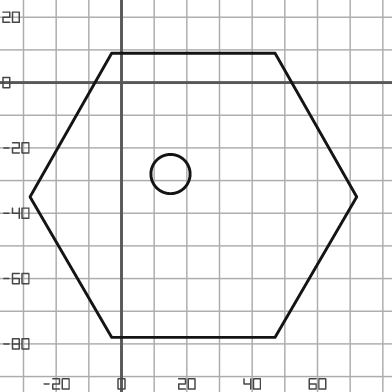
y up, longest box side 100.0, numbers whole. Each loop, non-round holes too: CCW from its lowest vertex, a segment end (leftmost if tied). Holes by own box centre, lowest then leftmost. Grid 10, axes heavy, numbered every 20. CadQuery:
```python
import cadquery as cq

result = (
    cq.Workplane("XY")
    .moveTo(-3.0, -78.0)
    .lineTo(47.0, -78.0)
    .lineTo(72.0, -35.0)
    .lineTo(47.0, 9.0)
    .lineTo(-3.0, 9.0)
    .lineTo(-28.0, -35.0)
    .close()
    .moveTo(15.0, -28.0)
    .circle(6.0)
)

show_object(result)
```